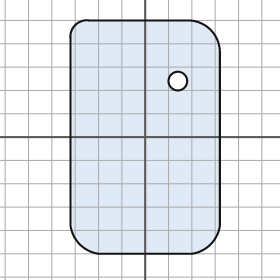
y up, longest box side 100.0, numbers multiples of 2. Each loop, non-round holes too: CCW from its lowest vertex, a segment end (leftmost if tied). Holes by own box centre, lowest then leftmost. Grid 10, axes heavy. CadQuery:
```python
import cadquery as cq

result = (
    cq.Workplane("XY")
    .moveTo(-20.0, -50.0)
    .lineTo(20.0, -50.0)
    .threePointArc((28.0, -46.0), (32.0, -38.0))
    .lineTo(32.0, 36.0)
    .threePointArc((28.0, 46.0), (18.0, 50.0))
    .lineTo(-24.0, 50.0)
    .threePointArc((-30.0, 48.0), (-32.0, 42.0))
    .lineTo(-32.0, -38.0)
    .threePointArc((-28.0, -46.0), (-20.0, -50.0))
    .close()
    .moveTo(14.0, 24.0)
    .circle(4.0)
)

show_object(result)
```